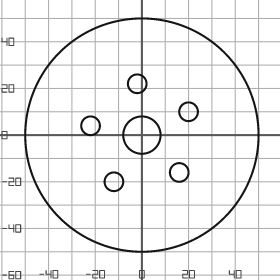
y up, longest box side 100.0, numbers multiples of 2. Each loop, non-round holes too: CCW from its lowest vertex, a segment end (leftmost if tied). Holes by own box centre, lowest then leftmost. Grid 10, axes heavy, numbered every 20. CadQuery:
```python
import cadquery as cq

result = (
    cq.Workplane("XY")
    .moveTo(0.0, 0.0)
    .circle(50.0)
    .moveTo(-12.0, -20.0)
    .circle(4.0)
    .moveTo(16.0, -16.0)
    .circle(4.0)
    .moveTo(0.0, 0.0)
    .circle(8.0)
    .moveTo(-22.0, 4.0)
    .circle(4.0)
    .moveTo(20.0, 10.0)
    .circle(4.0)
    .moveTo(-2.0, 22.0)
    .circle(4.0)
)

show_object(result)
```